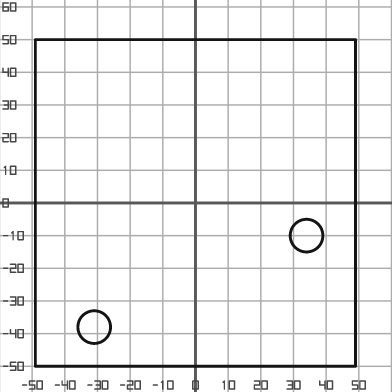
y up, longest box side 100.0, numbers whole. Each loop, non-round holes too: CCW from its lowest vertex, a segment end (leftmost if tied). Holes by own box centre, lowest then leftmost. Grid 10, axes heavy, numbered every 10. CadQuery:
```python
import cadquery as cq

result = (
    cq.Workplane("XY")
    .moveTo(-49.0, -50.0)
    .lineTo(49.0, -50.0)
    .lineTo(49.0, 50.0)
    .lineTo(-49.0, 50.0)
    .close()
    .moveTo(-31.0, -38.0)
    .circle(5.0)
    .moveTo(34.0, -10.0)
    .circle(5.0)
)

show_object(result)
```